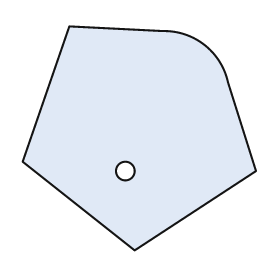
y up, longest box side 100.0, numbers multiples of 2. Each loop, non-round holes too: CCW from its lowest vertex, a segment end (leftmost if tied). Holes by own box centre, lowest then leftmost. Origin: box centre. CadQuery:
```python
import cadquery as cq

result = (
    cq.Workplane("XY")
    .moveTo(-2.0, -48.0)
    .lineTo(50.0, -14.0)
    .lineTo(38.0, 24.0)
    .threePointArc((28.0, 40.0), (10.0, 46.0))
    .lineTo(-30.0, 48.0)
    .lineTo(-50.0, -10.0)
    .close()
    .moveTo(-6.0, -14.0)
    .circle(4.0)
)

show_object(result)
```